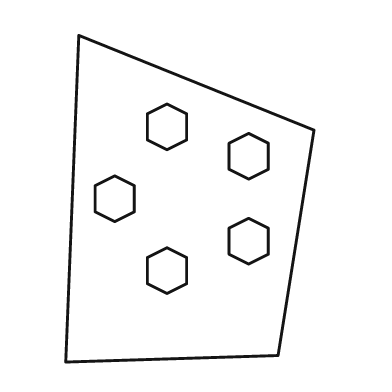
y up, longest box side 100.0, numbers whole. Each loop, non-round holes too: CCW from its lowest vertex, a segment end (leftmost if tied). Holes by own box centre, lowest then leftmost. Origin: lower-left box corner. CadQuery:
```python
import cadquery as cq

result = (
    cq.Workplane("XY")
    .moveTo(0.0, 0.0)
    .lineTo(65.0, 2.0)
    .lineTo(76.0, 71.0)
    .lineTo(4.0, 100.0)
    .close()
    .moveTo(31.0, 21.0)
    .lineTo(37.0, 24.0)
    .lineTo(37.0, 32.0)
    .lineTo(31.0, 35.0)
    .lineTo(25.0, 32.0)
    .lineTo(25.0, 24.0)
    .close()
    .moveTo(56.0, 30.0)
    .lineTo(62.0, 33.0)
    .lineTo(62.0, 41.0)
    .lineTo(56.0, 44.0)
    .lineTo(50.0, 41.0)
    .lineTo(50.0, 33.0)
    .close()
    .moveTo(15.0, 43.0)
    .lineTo(21.0, 46.0)
    .lineTo(21.0, 54.0)
    .lineTo(15.0, 57.0)
    .lineTo(9.0, 54.0)
    .lineTo(9.0, 46.0)
    .close()
    .moveTo(56.0, 56.0)
    .lineTo(62.0, 59.0)
    .lineTo(62.0, 67.0)
    .lineTo(56.0, 70.0)
    .lineTo(50.0, 67.0)
    .lineTo(50.0, 59.0)
    .close()
    .moveTo(31.0, 65.0)
    .lineTo(37.0, 68.0)
    .lineTo(37.0, 76.0)
    .lineTo(31.0, 79.0)
    .lineTo(25.0, 76.0)
    .lineTo(25.0, 68.0)
    .close()
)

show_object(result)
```